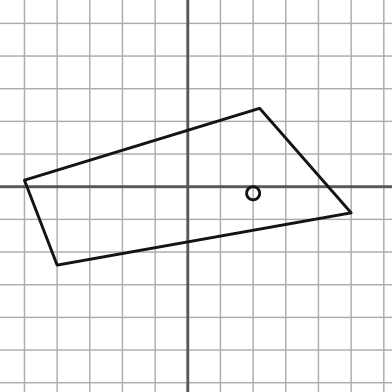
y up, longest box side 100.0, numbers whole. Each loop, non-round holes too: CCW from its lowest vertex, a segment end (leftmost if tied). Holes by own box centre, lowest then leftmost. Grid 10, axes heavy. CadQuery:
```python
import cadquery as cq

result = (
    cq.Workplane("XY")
    .moveTo(-40.0, -24.0)
    .lineTo(50.0, -8.0)
    .lineTo(22.0, 24.0)
    .lineTo(-50.0, 2.0)
    .close()
    .moveTo(20.0, -2.0)
    .circle(2.0)
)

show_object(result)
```